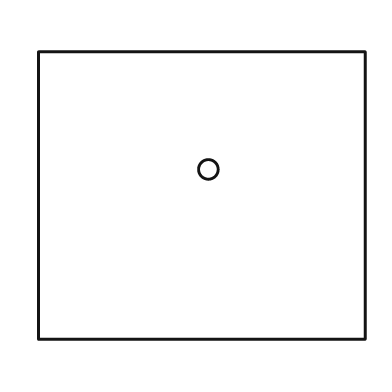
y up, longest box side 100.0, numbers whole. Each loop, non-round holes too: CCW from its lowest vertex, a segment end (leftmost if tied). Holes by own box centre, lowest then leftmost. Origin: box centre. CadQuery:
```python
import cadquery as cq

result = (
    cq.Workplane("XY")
    .moveTo(-50.0, -44.0)
    .lineTo(50.0, -44.0)
    .lineTo(50.0, 44.0)
    .lineTo(-50.0, 44.0)
    .close()
    .moveTo(2.0, 8.0)
    .circle(3.0)
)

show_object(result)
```